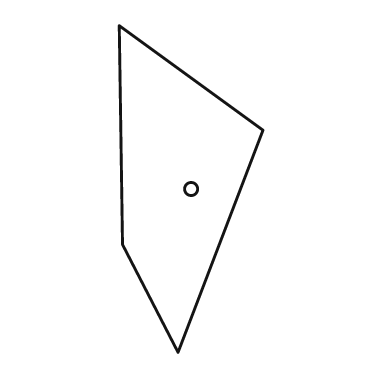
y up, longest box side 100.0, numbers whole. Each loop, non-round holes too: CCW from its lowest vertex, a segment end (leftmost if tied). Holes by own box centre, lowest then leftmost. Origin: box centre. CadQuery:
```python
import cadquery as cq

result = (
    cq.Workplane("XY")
    .moveTo(-4.0, -50.0)
    .lineTo(22.0, 18.0)
    .lineTo(-22.0, 50.0)
    .lineTo(-21.0, -17.0)
    .close()
    .moveTo(0.0, 0.0)
    .circle(2.0)
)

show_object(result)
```